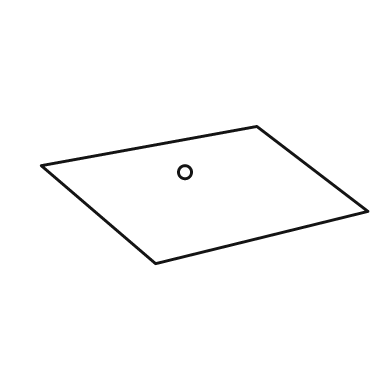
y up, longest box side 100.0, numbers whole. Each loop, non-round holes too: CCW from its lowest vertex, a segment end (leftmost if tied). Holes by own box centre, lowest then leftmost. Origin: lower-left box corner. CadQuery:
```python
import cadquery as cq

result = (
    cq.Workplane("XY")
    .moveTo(35.0, 0.0)
    .lineTo(100.0, 16.0)
    .lineTo(66.0, 42.0)
    .lineTo(0.0, 30.0)
    .close()
    .moveTo(44.0, 28.0)
    .circle(2.0)
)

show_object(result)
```